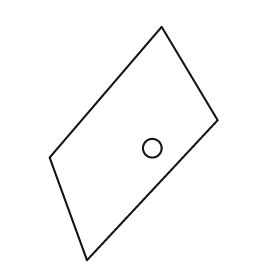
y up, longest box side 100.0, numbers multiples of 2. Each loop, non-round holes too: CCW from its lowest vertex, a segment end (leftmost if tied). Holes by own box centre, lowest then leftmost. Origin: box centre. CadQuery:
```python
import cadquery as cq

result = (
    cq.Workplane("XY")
    .moveTo(-20.0, -50.0)
    .lineTo(36.0, 10.0)
    .lineTo(12.0, 50.0)
    .lineTo(-36.0, -6.0)
    .close()
    .moveTo(8.0, -2.0)
    .circle(4.0)
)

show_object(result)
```